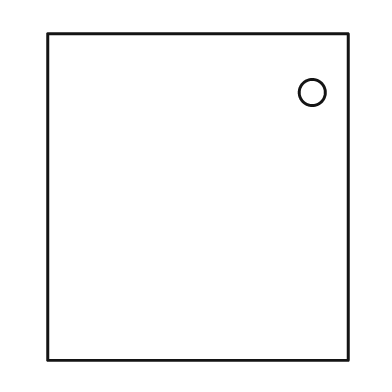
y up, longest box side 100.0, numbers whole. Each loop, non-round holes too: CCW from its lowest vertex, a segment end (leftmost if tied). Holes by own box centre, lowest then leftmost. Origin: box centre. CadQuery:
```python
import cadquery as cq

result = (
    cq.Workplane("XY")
    .moveTo(-46.0, -50.0)
    .lineTo(46.0, -50.0)
    .lineTo(46.0, 50.0)
    .lineTo(-46.0, 50.0)
    .close()
    .moveTo(35.0, 32.0)
    .circle(4.0)
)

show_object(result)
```